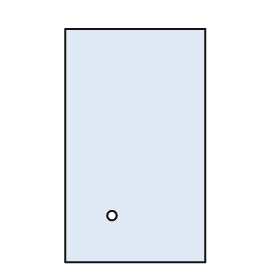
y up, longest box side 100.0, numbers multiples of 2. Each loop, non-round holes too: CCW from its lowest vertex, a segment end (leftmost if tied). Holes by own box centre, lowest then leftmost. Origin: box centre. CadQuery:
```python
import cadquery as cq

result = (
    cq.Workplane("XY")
    .moveTo(-30.0, -50.0)
    .lineTo(30.0, -50.0)
    .lineTo(30.0, 50.0)
    .lineTo(-30.0, 50.0)
    .close()
    .moveTo(-10.0, -30.0)
    .circle(2.0)
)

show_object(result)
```